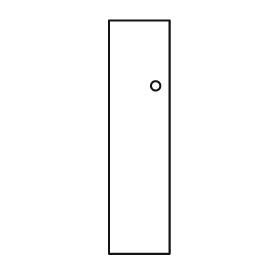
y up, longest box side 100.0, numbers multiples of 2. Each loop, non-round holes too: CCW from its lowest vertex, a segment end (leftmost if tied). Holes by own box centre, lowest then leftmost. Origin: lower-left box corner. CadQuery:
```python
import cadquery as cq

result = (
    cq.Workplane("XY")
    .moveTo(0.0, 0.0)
    .lineTo(26.0, 0.0)
    .lineTo(26.0, 100.0)
    .lineTo(0.0, 100.0)
    .close()
    .moveTo(20.0, 72.0)
    .circle(2.0)
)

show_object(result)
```